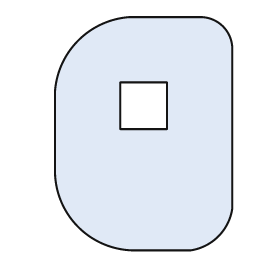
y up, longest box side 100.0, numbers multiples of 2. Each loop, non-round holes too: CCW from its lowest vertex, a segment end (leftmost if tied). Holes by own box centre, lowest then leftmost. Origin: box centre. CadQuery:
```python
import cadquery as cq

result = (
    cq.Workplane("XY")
    .moveTo(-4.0, -50.0)
    .lineTo(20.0, -50.0)
    .threePointArc((32.0, -44.0), (38.0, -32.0))
    .lineTo(38.0, 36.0)
    .threePointArc((34.0, 46.0), (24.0, 50.0))
    .lineTo(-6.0, 50.0)
    .threePointArc((-28.0, 40.0), (-38.0, 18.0))
    .lineTo(-38.0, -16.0)
    .threePointArc((-28.0, -40.0), (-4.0, -50.0))
    .close()
    .moveTo(-10.0, 2.0)
    .lineTo(10.0, 2.0)
    .lineTo(10.0, 22.0)
    .lineTo(-10.0, 22.0)
    .close()
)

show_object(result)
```